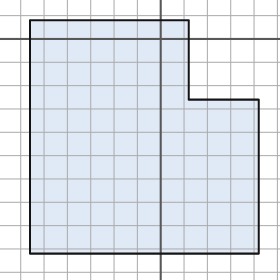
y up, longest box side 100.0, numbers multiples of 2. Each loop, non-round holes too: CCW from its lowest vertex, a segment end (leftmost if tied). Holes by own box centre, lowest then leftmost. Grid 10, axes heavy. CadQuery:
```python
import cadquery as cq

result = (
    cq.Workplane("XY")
    .moveTo(-56.0, -92.0)
    .lineTo(42.0, -92.0)
    .lineTo(42.0, -26.0)
    .lineTo(12.0, -26.0)
    .lineTo(12.0, 8.0)
    .lineTo(-56.0, 8.0)
    .close()
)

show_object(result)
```